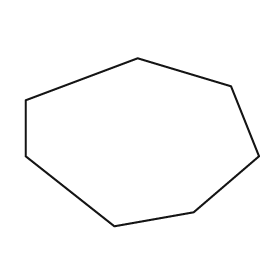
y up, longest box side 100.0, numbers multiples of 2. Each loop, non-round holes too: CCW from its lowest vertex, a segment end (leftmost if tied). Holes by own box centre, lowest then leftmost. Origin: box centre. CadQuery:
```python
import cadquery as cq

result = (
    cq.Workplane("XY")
    .moveTo(-12.0, -36.0)
    .lineTo(22.0, -30.0)
    .lineTo(50.0, -6.0)
    .lineTo(38.0, 24.0)
    .lineTo(-2.0, 36.0)
    .lineTo(-50.0, 18.0)
    .lineTo(-50.0, -6.0)
    .close()
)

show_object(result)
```